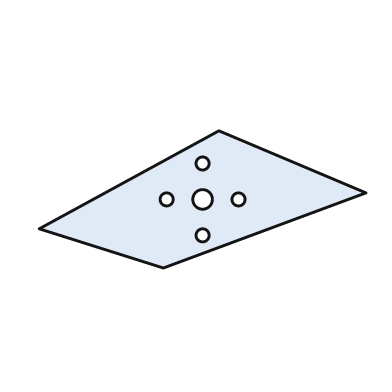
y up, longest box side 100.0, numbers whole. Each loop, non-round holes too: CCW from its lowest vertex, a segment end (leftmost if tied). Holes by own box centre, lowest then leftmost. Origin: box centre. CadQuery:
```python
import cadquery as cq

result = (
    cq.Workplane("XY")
    .moveTo(-12.0, -21.0)
    .lineTo(50.0, 2.0)
    .lineTo(5.0, 21.0)
    .lineTo(-50.0, -9.0)
    .close()
    .moveTo(0.0, -11.0)
    .circle(2.0)
    .moveTo(-11.0, 0.0)
    .circle(2.0)
    .moveTo(0.0, 0.0)
    .circle(3.0)
    .moveTo(11.0, 0.0)
    .circle(2.0)
    .moveTo(0.0, 11.0)
    .circle(2.0)
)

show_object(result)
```